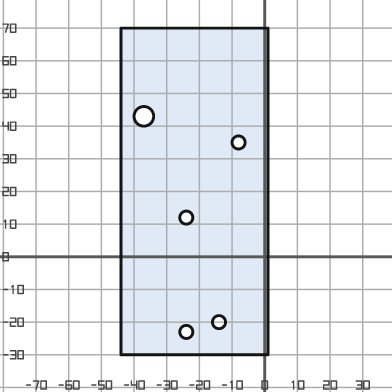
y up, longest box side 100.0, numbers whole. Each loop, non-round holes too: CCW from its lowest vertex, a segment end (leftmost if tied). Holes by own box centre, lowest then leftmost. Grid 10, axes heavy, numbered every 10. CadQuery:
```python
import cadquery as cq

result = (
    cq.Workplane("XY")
    .moveTo(-44.0, -30.0)
    .lineTo(1.0, -30.0)
    .lineTo(1.0, 70.0)
    .lineTo(-44.0, 70.0)
    .close()
    .moveTo(-24.0, -23.0)
    .circle(2.0)
    .moveTo(-14.0, -20.0)
    .circle(2.0)
    .moveTo(-24.0, 12.0)
    .circle(2.0)
    .moveTo(-8.0, 35.0)
    .circle(2.0)
    .moveTo(-37.0, 43.0)
    .circle(3.0)
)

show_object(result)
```